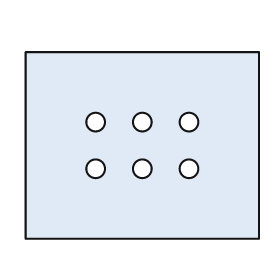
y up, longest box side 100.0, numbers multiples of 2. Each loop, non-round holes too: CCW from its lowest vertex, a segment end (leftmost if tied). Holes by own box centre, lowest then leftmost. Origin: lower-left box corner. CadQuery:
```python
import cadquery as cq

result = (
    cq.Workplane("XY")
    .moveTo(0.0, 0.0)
    .lineTo(100.0, 0.0)
    .lineTo(100.0, 80.0)
    .lineTo(0.0, 80.0)
    .close()
    .moveTo(30.0, 30.0)
    .circle(4.0)
    .moveTo(50.0, 30.0)
    .circle(4.0)
    .moveTo(70.0, 30.0)
    .circle(4.0)
    .moveTo(30.0, 50.0)
    .circle(4.0)
    .moveTo(50.0, 50.0)
    .circle(4.0)
    .moveTo(70.0, 50.0)
    .circle(4.0)
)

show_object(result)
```